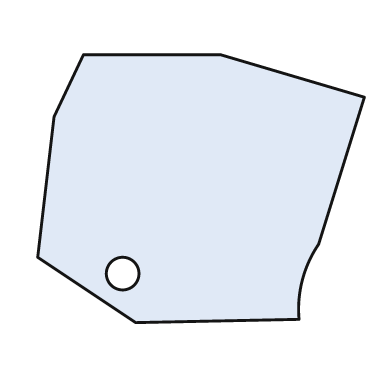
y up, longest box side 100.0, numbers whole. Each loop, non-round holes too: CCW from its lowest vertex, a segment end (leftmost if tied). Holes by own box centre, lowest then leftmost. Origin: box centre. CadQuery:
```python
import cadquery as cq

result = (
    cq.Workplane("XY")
    .moveTo(-20.0, -41.0)
    .lineTo(30.0, -40.0)
    .threePointArc((31.0, -28.0), (36.0, -17.0))
    .lineTo(50.0, 28.0)
    .lineTo(6.0, 41.0)
    .lineTo(-36.0, 41.0)
    .lineTo(-45.0, 22.0)
    .lineTo(-50.0, -21.0)
    .close()
    .moveTo(-24.0, -26.0)
    .circle(5.0)
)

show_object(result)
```